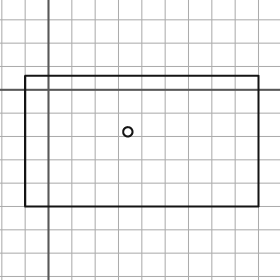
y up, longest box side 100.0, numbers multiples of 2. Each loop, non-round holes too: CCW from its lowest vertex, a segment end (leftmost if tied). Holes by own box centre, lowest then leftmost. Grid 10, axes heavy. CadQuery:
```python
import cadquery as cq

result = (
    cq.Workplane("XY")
    .moveTo(-10.0, -50.0)
    .lineTo(90.0, -50.0)
    .lineTo(90.0, 6.0)
    .lineTo(-10.0, 6.0)
    .close()
    .moveTo(34.0, -18.0)
    .circle(2.0)
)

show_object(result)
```